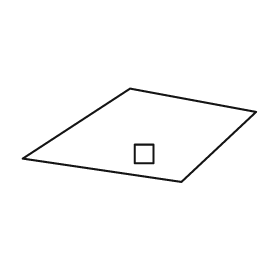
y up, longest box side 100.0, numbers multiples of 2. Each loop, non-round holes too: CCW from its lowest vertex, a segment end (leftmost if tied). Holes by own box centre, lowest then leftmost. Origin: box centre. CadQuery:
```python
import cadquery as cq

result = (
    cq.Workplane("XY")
    .moveTo(18.0, -20.0)
    .lineTo(50.0, 10.0)
    .lineTo(-4.0, 20.0)
    .lineTo(-50.0, -10.0)
    .close()
    .moveTo(-2.0, -12.0)
    .lineTo(6.0, -12.0)
    .lineTo(6.0, -4.0)
    .lineTo(-2.0, -4.0)
    .close()
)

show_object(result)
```